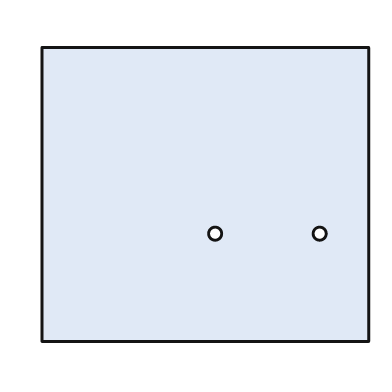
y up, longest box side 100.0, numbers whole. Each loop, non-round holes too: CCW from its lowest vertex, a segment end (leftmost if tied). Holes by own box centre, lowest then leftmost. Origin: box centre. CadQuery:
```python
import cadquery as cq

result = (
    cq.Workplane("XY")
    .moveTo(-50.0, -45.0)
    .lineTo(50.0, -45.0)
    .lineTo(50.0, 45.0)
    .lineTo(-50.0, 45.0)
    .close()
    .moveTo(3.0, -12.0)
    .circle(2.0)
    .moveTo(35.0, -12.0)
    .circle(2.0)
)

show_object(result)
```